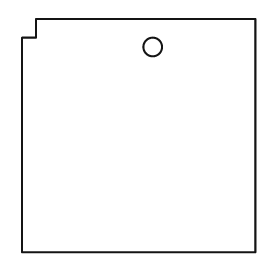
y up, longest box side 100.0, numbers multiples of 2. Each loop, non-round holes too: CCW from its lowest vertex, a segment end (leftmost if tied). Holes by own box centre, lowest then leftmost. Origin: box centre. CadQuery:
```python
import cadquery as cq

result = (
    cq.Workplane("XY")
    .moveTo(-50.0, -50.0)
    .lineTo(50.0, -50.0)
    .lineTo(50.0, 50.0)
    .lineTo(-44.0, 50.0)
    .lineTo(-44.0, 42.0)
    .lineTo(-50.0, 42.0)
    .close()
    .moveTo(6.0, 38.0)
    .circle(4.0)
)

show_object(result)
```